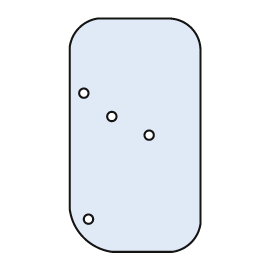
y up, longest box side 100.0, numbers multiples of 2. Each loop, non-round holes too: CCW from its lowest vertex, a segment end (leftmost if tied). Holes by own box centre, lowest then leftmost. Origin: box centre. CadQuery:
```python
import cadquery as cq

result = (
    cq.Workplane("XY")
    .moveTo(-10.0, -50.0)
    .lineTo(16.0, -50.0)
    .threePointArc((24.0, -46.0), (28.0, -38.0))
    .lineTo(28.0, 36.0)
    .threePointArc((24.0, 46.0), (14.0, 50.0))
    .lineTo(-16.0, 50.0)
    .threePointArc((-24.0, 46.0), (-28.0, 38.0))
    .lineTo(-28.0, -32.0)
    .threePointArc((-22.0, -44.0), (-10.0, -50.0))
    .close()
    .moveTo(-20.0, -36.0)
    .circle(2.0)
    .moveTo(6.0, 0.0)
    .circle(2.0)
    .moveTo(-10.0, 8.0)
    .circle(2.0)
    .moveTo(-22.0, 18.0)
    .circle(2.0)
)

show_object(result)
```